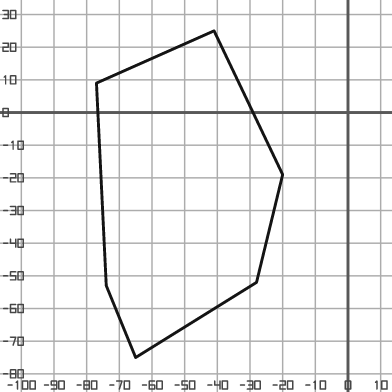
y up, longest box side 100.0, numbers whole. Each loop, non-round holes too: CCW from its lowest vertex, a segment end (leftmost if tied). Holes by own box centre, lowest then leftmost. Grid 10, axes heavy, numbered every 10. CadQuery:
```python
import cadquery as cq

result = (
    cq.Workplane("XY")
    .moveTo(-65.0, -75.0)
    .lineTo(-28.0, -52.0)
    .lineTo(-20.0, -19.0)
    .lineTo(-41.0, 25.0)
    .lineTo(-77.0, 9.0)
    .lineTo(-74.0, -53.0)
    .close()
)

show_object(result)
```